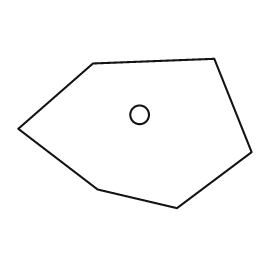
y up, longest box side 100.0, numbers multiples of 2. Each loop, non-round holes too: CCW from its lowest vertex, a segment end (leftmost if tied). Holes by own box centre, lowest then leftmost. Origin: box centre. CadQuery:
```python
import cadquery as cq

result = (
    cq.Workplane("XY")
    .moveTo(18.0, -32.0)
    .lineTo(50.0, -8.0)
    .lineTo(34.0, 32.0)
    .lineTo(-18.0, 30.0)
    .lineTo(-50.0, 2.0)
    .lineTo(-16.0, -24.0)
    .close()
    .moveTo(2.0, 8.0)
    .circle(4.0)
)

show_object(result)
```